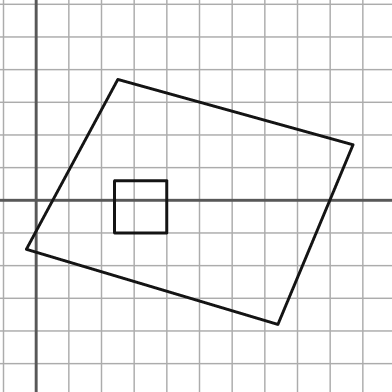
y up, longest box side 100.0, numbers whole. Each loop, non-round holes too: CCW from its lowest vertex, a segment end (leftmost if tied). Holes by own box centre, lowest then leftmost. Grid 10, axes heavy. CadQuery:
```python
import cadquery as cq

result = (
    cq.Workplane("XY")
    .moveTo(74.0, -38.0)
    .lineTo(97.0, 17.0)
    .lineTo(25.0, 37.0)
    .lineTo(-3.0, -15.0)
    .close()
    .moveTo(24.0, -10.0)
    .lineTo(40.0, -10.0)
    .lineTo(40.0, 6.0)
    .lineTo(24.0, 6.0)
    .close()
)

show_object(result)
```